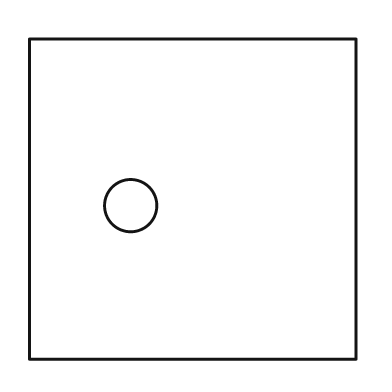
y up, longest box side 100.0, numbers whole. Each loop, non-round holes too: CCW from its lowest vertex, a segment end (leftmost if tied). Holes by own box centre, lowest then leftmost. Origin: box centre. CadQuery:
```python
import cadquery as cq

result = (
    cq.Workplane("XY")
    .moveTo(-50.0, -49.0)
    .lineTo(50.0, -49.0)
    .lineTo(50.0, 49.0)
    .lineTo(-50.0, 49.0)
    .close()
    .moveTo(-19.0, -2.0)
    .circle(8.0)
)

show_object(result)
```